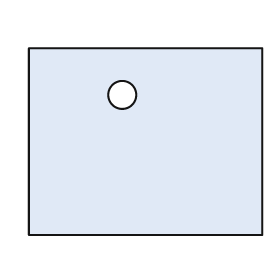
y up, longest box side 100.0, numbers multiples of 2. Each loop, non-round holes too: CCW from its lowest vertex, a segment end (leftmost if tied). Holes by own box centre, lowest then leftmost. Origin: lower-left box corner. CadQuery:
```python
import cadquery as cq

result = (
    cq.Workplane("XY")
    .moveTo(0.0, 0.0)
    .lineTo(100.0, 0.0)
    .lineTo(100.0, 80.0)
    .lineTo(0.0, 80.0)
    .close()
    .moveTo(40.0, 60.0)
    .circle(6.0)
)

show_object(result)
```